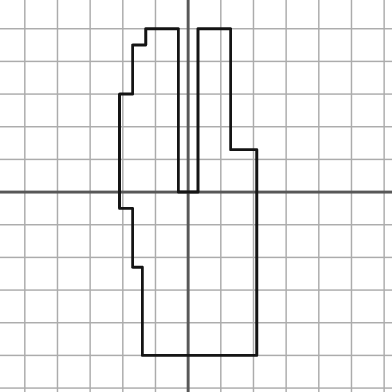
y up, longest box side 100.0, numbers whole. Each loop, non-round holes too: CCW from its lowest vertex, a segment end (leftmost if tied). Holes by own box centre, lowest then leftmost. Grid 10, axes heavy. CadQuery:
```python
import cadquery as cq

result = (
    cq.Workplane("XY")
    .moveTo(-14.0, -50.0)
    .lineTo(21.0, -50.0)
    .lineTo(21.0, 13.0)
    .lineTo(13.0, 13.0)
    .lineTo(13.0, 50.0)
    .lineTo(3.0, 50.0)
    .lineTo(3.0, 0.0)
    .lineTo(-3.0, 0.0)
    .lineTo(-3.0, 50.0)
    .lineTo(-13.0, 50.0)
    .lineTo(-13.0, 45.0)
    .lineTo(-17.0, 45.0)
    .lineTo(-17.0, 30.0)
    .lineTo(-21.0, 30.0)
    .lineTo(-21.0, -5.0)
    .lineTo(-17.0, -5.0)
    .lineTo(-17.0, -23.0)
    .lineTo(-14.0, -23.0)
    .close()
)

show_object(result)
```